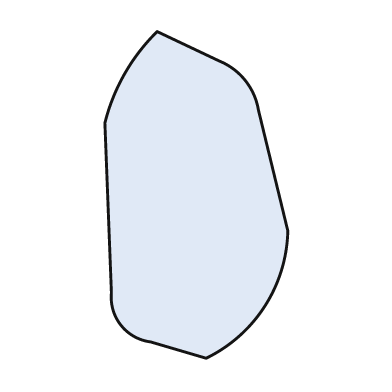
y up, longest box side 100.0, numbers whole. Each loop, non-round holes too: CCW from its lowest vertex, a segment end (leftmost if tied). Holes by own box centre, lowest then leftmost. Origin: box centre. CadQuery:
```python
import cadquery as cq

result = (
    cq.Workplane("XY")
    .moveTo(3.0, -50.0)
    .threePointArc((21.0, -34.0), (28.0, -11.0))
    .lineTo(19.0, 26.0)
    .threePointArc((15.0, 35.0), (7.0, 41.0))
    .lineTo(-12.0, 50.0)
    .threePointArc((-22.0, 37.0), (-28.0, 22.0))
    .lineTo(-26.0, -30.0)
    .threePointArc((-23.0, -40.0), (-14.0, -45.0))
    .close()
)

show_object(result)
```